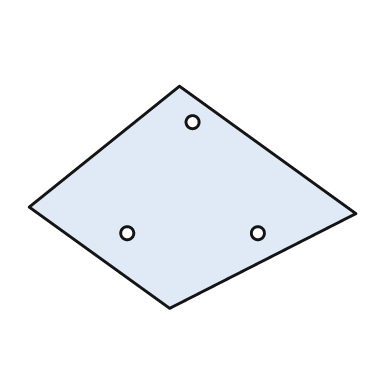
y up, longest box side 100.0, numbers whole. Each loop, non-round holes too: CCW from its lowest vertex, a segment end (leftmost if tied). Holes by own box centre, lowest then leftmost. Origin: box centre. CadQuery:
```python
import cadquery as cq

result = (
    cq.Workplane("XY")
    .moveTo(-7.0, -34.0)
    .lineTo(50.0, -5.0)
    .lineTo(-4.0, 34.0)
    .lineTo(-50.0, -3.0)
    .close()
    .moveTo(-20.0, -11.0)
    .circle(2.0)
    .moveTo(20.0, -11.0)
    .circle(2.0)
    .moveTo(0.0, 23.0)
    .circle(2.0)
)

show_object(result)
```